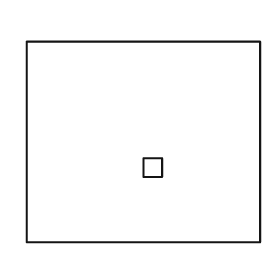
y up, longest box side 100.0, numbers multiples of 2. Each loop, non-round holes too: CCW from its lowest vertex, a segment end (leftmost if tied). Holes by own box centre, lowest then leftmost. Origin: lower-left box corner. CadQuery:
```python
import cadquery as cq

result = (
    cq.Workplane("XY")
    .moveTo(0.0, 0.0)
    .lineTo(100.0, 0.0)
    .lineTo(100.0, 86.0)
    .lineTo(0.0, 86.0)
    .close()
    .moveTo(50.0, 28.0)
    .lineTo(58.0, 28.0)
    .lineTo(58.0, 36.0)
    .lineTo(50.0, 36.0)
    .close()
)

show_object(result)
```